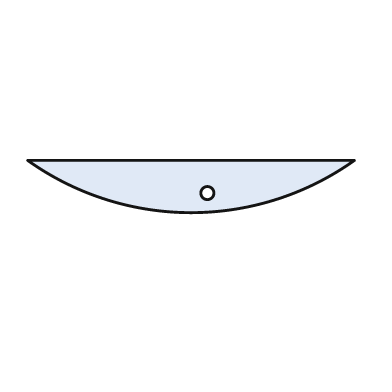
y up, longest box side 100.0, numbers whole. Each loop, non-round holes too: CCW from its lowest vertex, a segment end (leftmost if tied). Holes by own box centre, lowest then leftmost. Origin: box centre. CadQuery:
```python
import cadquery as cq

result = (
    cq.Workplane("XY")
    .moveTo(-50.0, 8.0)
    .threePointArc((0.0, -8.0), (50.0, 8.0))
    .close()
    .moveTo(5.0, -2.0)
    .circle(2.0)
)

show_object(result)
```